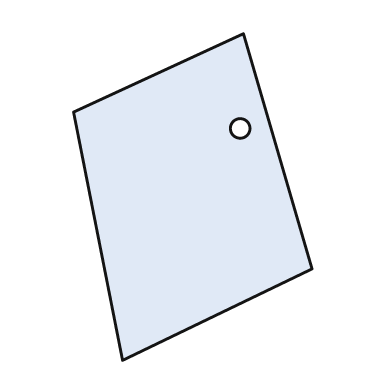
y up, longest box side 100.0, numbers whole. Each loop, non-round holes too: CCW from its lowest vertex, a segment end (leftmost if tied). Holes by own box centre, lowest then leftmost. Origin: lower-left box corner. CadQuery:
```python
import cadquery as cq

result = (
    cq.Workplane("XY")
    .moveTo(15.0, 0.0)
    .lineTo(73.0, 28.0)
    .lineTo(52.0, 100.0)
    .lineTo(0.0, 76.0)
    .close()
    .moveTo(51.0, 71.0)
    .circle(3.0)
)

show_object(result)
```